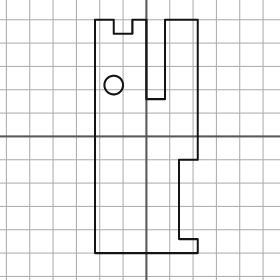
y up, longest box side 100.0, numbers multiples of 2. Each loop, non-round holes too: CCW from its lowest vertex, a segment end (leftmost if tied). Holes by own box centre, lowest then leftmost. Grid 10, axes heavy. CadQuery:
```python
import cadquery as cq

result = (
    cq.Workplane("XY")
    .moveTo(-22.0, -50.0)
    .lineTo(22.0, -50.0)
    .lineTo(22.0, -44.0)
    .lineTo(14.0, -44.0)
    .lineTo(14.0, -10.0)
    .lineTo(22.0, -10.0)
    .lineTo(22.0, 50.0)
    .lineTo(8.0, 50.0)
    .lineTo(8.0, 16.0)
    .lineTo(0.0, 16.0)
    .lineTo(0.0, 50.0)
    .lineTo(-6.0, 50.0)
    .lineTo(-6.0, 44.0)
    .lineTo(-14.0, 44.0)
    .lineTo(-14.0, 50.0)
    .lineTo(-22.0, 50.0)
    .close()
    .moveTo(-14.0, 22.0)
    .circle(4.0)
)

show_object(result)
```